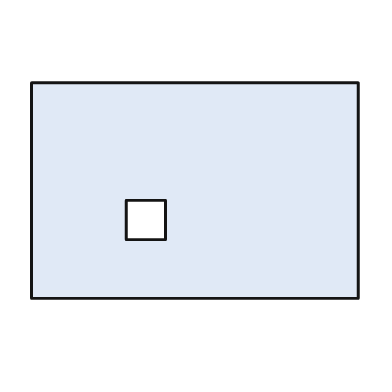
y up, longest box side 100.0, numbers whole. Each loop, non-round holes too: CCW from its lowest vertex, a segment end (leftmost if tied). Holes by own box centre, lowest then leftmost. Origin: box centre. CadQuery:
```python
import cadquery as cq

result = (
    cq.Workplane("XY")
    .moveTo(-50.0, -33.0)
    .lineTo(50.0, -33.0)
    .lineTo(50.0, 33.0)
    .lineTo(-50.0, 33.0)
    .close()
    .moveTo(-21.0, -15.0)
    .lineTo(-9.0, -15.0)
    .lineTo(-9.0, -3.0)
    .lineTo(-21.0, -3.0)
    .close()
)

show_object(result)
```